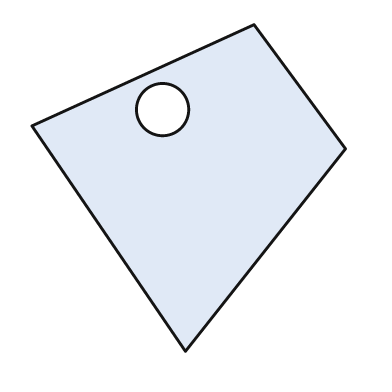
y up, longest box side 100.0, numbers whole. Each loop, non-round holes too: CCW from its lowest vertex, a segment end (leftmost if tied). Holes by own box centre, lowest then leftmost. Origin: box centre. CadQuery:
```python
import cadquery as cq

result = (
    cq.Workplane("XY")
    .moveTo(-1.0, -50.0)
    .lineTo(48.0, 12.0)
    .lineTo(20.0, 50.0)
    .lineTo(-48.0, 19.0)
    .close()
    .moveTo(-8.0, 24.0)
    .circle(8.0)
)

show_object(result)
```